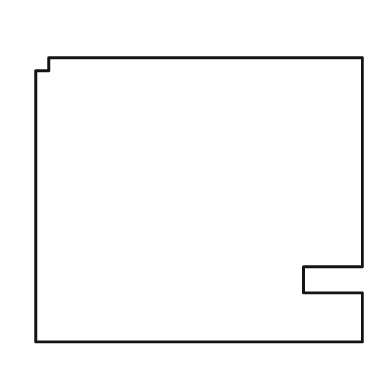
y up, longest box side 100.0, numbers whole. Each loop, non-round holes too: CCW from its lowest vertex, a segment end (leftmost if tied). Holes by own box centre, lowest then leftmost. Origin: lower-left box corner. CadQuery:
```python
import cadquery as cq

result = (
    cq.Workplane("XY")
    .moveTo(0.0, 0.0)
    .lineTo(100.0, 0.0)
    .lineTo(100.0, 15.0)
    .lineTo(82.0, 15.0)
    .lineTo(82.0, 23.0)
    .lineTo(100.0, 23.0)
    .lineTo(100.0, 87.0)
    .lineTo(4.0, 87.0)
    .lineTo(4.0, 83.0)
    .lineTo(0.0, 83.0)
    .close()
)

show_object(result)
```